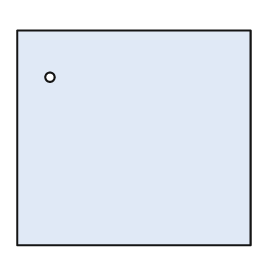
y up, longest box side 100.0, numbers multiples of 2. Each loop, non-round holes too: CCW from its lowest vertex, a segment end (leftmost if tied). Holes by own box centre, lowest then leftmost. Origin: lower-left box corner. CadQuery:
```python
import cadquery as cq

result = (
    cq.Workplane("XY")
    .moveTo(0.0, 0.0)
    .lineTo(100.0, 0.0)
    .lineTo(100.0, 92.0)
    .lineTo(0.0, 92.0)
    .close()
    .moveTo(14.0, 72.0)
    .circle(2.0)
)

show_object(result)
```